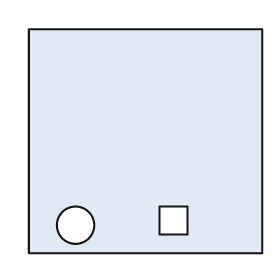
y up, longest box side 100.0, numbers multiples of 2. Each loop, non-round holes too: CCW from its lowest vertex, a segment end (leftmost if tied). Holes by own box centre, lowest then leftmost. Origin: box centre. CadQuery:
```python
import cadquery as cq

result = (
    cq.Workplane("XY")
    .moveTo(-50.0, -48.0)
    .lineTo(50.0, -48.0)
    .lineTo(50.0, 48.0)
    .lineTo(-50.0, 48.0)
    .close()
    .moveTo(-30.0, -36.0)
    .circle(8.0)
    .moveTo(6.0, -40.0)
    .lineTo(18.0, -40.0)
    .lineTo(18.0, -28.0)
    .lineTo(6.0, -28.0)
    .close()
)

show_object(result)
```